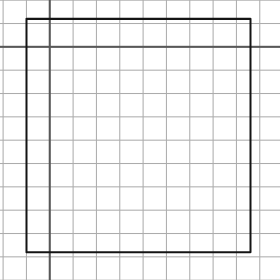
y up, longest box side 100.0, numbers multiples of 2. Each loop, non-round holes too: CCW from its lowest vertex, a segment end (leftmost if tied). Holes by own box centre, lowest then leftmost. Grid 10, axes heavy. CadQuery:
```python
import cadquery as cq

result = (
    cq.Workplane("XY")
    .moveTo(-10.0, -88.0)
    .lineTo(86.0, -88.0)
    .lineTo(86.0, 12.0)
    .lineTo(-10.0, 12.0)
    .close()
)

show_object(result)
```